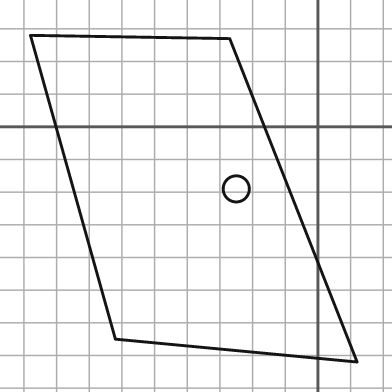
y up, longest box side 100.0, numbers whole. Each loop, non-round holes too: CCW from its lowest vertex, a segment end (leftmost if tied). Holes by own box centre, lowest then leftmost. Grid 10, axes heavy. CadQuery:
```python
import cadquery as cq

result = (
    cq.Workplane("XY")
    .moveTo(12.0, -72.0)
    .lineTo(-27.0, 27.0)
    .lineTo(-88.0, 28.0)
    .lineTo(-62.0, -65.0)
    .close()
    .moveTo(-25.0, -19.0)
    .circle(4.0)
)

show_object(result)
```